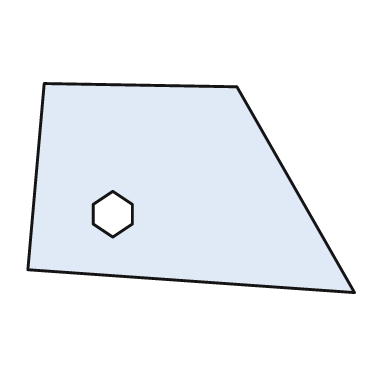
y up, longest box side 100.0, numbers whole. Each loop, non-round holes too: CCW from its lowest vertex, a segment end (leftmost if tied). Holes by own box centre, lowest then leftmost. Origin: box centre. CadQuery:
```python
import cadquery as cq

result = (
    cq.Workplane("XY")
    .moveTo(50.0, -32.0)
    .lineTo(14.0, 31.0)
    .lineTo(-45.0, 32.0)
    .lineTo(-50.0, -25.0)
    .close()
    .moveTo(-24.0, -15.0)
    .lineTo(-18.0, -11.0)
    .lineTo(-18.0, -5.0)
    .lineTo(-24.0, -1.0)
    .lineTo(-30.0, -5.0)
    .lineTo(-30.0, -11.0)
    .close()
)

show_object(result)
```